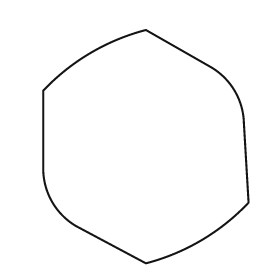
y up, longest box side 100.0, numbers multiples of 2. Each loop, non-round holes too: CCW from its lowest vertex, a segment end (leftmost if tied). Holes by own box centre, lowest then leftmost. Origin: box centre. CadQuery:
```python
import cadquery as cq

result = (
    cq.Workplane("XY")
    .moveTo(0.0, -50.0)
    .threePointArc((24.0, -40.0), (44.0, -24.0))
    .lineTo(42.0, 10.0)
    .threePointArc((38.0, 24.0), (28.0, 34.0))
    .lineTo(0.0, 50.0)
    .threePointArc((-24.0, 40.0), (-44.0, 24.0))
    .lineTo(-44.0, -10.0)
    .threePointArc((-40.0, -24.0), (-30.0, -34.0))
    .close()
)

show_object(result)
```